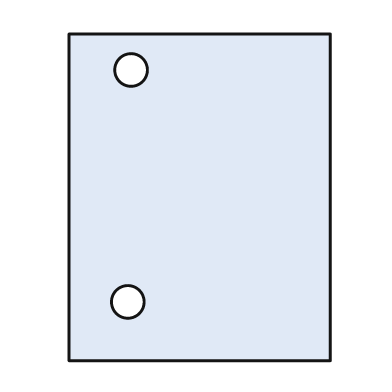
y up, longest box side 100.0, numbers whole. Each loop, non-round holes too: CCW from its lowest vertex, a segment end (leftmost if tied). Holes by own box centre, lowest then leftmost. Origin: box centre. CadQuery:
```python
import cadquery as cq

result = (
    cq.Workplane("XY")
    .moveTo(-40.0, -50.0)
    .lineTo(40.0, -50.0)
    .lineTo(40.0, 50.0)
    .lineTo(-40.0, 50.0)
    .close()
    .moveTo(-22.0, -32.0)
    .circle(5.0)
    .moveTo(-21.0, 39.0)
    .circle(5.0)
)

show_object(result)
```